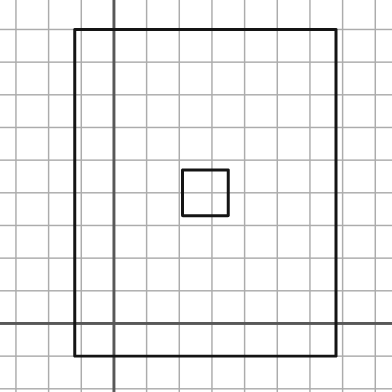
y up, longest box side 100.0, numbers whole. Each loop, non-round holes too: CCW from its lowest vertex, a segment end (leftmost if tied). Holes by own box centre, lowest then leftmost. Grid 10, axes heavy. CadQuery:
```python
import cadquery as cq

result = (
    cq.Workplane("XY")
    .moveTo(-12.0, -10.0)
    .lineTo(68.0, -10.0)
    .lineTo(68.0, 90.0)
    .lineTo(-12.0, 90.0)
    .close()
    .moveTo(21.0, 33.0)
    .lineTo(35.0, 33.0)
    .lineTo(35.0, 47.0)
    .lineTo(21.0, 47.0)
    .close()
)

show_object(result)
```